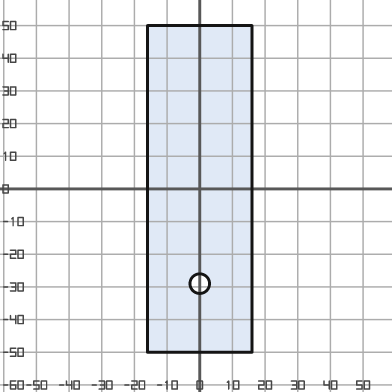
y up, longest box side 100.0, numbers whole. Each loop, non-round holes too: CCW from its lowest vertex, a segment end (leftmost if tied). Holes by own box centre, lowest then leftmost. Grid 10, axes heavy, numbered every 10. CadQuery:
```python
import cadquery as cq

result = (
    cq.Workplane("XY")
    .moveTo(-16.0, -50.0)
    .lineTo(16.0, -50.0)
    .lineTo(16.0, 50.0)
    .lineTo(-16.0, 50.0)
    .close()
    .moveTo(0.0, -29.0)
    .circle(3.0)
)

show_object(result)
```